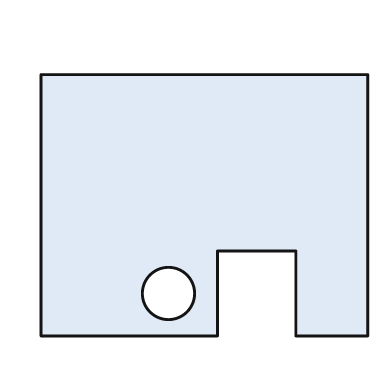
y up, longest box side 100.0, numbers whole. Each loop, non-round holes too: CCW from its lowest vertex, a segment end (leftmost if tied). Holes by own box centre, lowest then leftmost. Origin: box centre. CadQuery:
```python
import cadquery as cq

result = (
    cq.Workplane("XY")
    .moveTo(-50.0, -40.0)
    .lineTo(4.0, -40.0)
    .lineTo(4.0, -14.0)
    .lineTo(28.0, -14.0)
    .lineTo(28.0, -40.0)
    .lineTo(50.0, -40.0)
    .lineTo(50.0, 40.0)
    .lineTo(-50.0, 40.0)
    .close()
    .moveTo(-11.0, -27.0)
    .circle(8.0)
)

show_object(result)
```